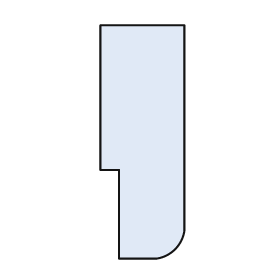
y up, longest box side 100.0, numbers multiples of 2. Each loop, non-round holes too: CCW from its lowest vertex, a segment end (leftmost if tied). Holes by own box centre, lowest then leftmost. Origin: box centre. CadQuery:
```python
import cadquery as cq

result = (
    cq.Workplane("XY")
    .moveTo(-10.0, -50.0)
    .lineTo(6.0, -50.0)
    .threePointArc((14.0, -46.0), (18.0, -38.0))
    .lineTo(18.0, 50.0)
    .lineTo(-18.0, 50.0)
    .lineTo(-18.0, -12.0)
    .lineTo(-10.0, -12.0)
    .close()
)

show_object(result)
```